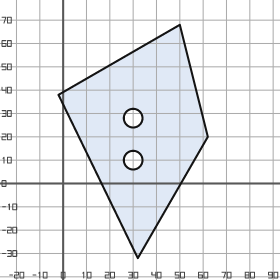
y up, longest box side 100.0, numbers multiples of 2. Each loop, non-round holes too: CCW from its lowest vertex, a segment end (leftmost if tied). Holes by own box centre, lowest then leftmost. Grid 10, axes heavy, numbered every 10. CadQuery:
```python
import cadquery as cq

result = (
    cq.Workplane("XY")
    .moveTo(32.0, -32.0)
    .lineTo(62.0, 20.0)
    .lineTo(50.0, 68.0)
    .lineTo(-2.0, 38.0)
    .close()
    .moveTo(30.0, 10.0)
    .circle(4.0)
    .moveTo(30.0, 28.0)
    .circle(4.0)
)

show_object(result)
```